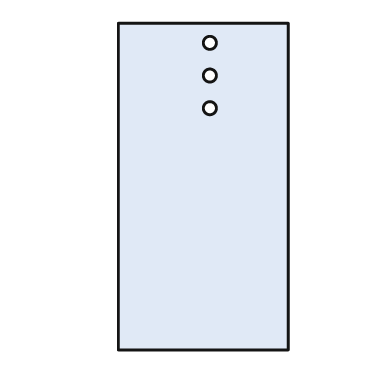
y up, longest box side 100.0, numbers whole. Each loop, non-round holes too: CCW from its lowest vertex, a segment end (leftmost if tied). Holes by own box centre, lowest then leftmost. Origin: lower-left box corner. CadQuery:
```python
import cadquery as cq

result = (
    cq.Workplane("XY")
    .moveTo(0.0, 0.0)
    .lineTo(52.0, 0.0)
    .lineTo(52.0, 100.0)
    .lineTo(0.0, 100.0)
    .close()
    .moveTo(28.0, 74.0)
    .circle(2.0)
    .moveTo(28.0, 84.0)
    .circle(2.0)
    .moveTo(28.0, 94.0)
    .circle(2.0)
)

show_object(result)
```